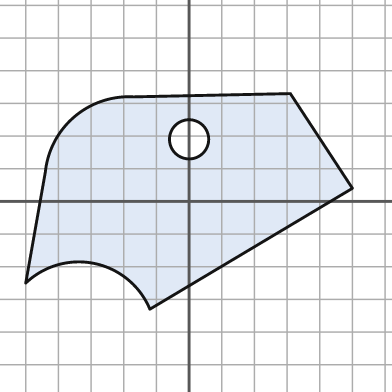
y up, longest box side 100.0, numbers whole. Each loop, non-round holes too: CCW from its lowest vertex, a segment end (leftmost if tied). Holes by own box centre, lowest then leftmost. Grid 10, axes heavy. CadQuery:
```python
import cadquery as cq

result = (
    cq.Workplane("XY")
    .moveTo(-12.0, -33.0)
    .lineTo(50.0, 4.0)
    .lineTo(31.0, 33.0)
    .lineTo(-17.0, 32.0)
    .threePointArc((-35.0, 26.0), (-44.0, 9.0))
    .lineTo(-50.0, -25.0)
    .threePointArc((-29.0, -19.0), (-12.0, -33.0))
    .close()
    .moveTo(0.0, 19.0)
    .circle(6.0)
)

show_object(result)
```